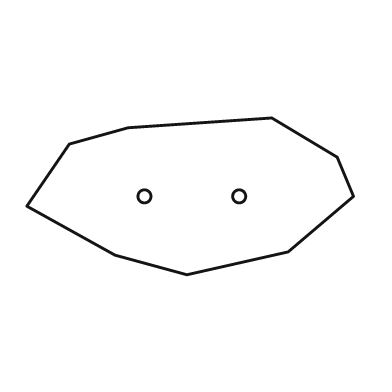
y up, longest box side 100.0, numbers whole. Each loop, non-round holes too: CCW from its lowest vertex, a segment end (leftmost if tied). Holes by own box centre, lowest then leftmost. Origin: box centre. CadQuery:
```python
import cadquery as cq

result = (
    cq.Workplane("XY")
    .moveTo(-1.0, -24.0)
    .lineTo(30.0, -17.0)
    .lineTo(50.0, 0.0)
    .lineTo(45.0, 12.0)
    .lineTo(25.0, 24.0)
    .lineTo(-19.0, 21.0)
    .lineTo(-37.0, 16.0)
    .lineTo(-50.0, -3.0)
    .lineTo(-23.0, -18.0)
    .close()
    .moveTo(-14.0, 0.0)
    .circle(2.0)
    .moveTo(15.0, 0.0)
    .circle(2.0)
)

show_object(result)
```